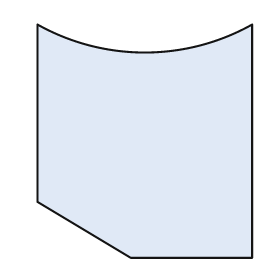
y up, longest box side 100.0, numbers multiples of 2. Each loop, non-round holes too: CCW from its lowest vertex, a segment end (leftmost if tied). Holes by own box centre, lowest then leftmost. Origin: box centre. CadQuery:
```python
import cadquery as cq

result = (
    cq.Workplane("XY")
    .moveTo(-6.0, -50.0)
    .lineTo(46.0, -50.0)
    .lineTo(46.0, 50.0)
    .threePointArc((0.0, 38.0), (-46.0, 50.0))
    .lineTo(-46.0, -26.0)
    .close()
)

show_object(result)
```